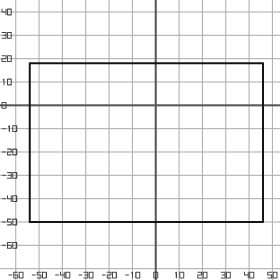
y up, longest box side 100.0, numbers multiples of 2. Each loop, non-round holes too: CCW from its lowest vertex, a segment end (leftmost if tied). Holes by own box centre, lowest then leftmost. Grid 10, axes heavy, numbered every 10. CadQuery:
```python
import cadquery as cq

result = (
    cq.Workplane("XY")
    .moveTo(-54.0, -50.0)
    .lineTo(46.0, -50.0)
    .lineTo(46.0, 18.0)
    .lineTo(-54.0, 18.0)
    .close()
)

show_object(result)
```